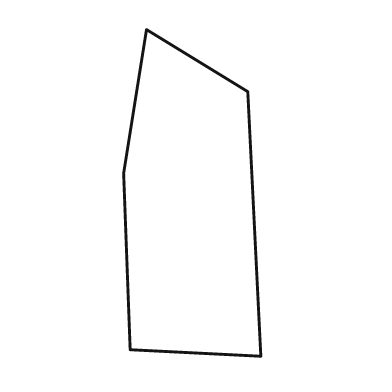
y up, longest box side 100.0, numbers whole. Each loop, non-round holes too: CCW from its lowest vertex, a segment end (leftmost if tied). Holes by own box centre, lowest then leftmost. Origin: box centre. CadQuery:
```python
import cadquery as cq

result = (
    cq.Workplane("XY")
    .moveTo(21.0, -50.0)
    .lineTo(17.0, 31.0)
    .lineTo(-14.0, 50.0)
    .lineTo(-21.0, 6.0)
    .lineTo(-19.0, -48.0)
    .close()
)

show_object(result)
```